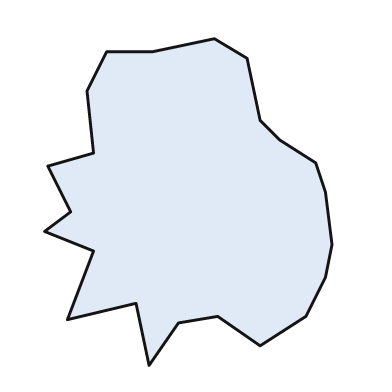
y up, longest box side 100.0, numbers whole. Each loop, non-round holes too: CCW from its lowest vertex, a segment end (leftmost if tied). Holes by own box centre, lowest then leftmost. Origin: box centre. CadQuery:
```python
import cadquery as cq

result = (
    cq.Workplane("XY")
    .moveTo(-12.0, -50.0)
    .lineTo(-3.0, -37.0)
    .lineTo(9.0, -35.0)
    .lineTo(22.0, -44.0)
    .lineTo(36.0, -35.0)
    .lineTo(42.0, -23.0)
    .lineTo(44.0, -13.0)
    .lineTo(42.0, 3.0)
    .lineTo(39.0, 12.0)
    .lineTo(28.0, 19.0)
    .lineTo(22.0, 25.0)
    .lineTo(18.0, 44.0)
    .lineTo(8.0, 50.0)
    .lineTo(-11.0, 46.0)
    .lineTo(-25.0, 46.0)
    .lineTo(-31.0, 34.0)
    .lineTo(-29.0, 15.0)
    .lineTo(-43.0, 11.0)
    .lineTo(-36.0, -3.0)
    .lineTo(-44.0, -9.0)
    .lineTo(-29.0, -15.0)
    .lineTo(-37.0, -36.0)
    .lineTo(-16.0, -31.0)
    .close()
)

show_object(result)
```